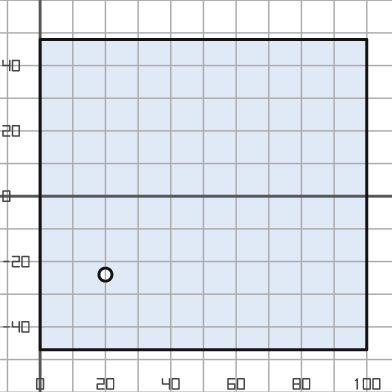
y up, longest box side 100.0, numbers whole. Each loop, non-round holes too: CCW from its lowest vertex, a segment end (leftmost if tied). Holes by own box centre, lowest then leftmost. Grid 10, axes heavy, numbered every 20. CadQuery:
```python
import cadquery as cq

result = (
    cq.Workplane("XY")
    .moveTo(0.0, -47.0)
    .lineTo(100.0, -47.0)
    .lineTo(100.0, 48.0)
    .lineTo(0.0, 48.0)
    .close()
    .moveTo(20.0, -24.0)
    .circle(2.0)
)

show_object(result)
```